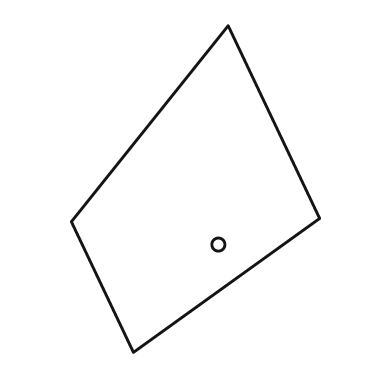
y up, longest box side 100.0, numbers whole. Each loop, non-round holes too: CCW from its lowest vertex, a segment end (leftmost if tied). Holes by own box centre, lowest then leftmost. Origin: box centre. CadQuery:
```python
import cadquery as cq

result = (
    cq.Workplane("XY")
    .moveTo(-19.0, -50.0)
    .lineTo(38.0, -9.0)
    .lineTo(10.0, 50.0)
    .lineTo(-38.0, -10.0)
    .close()
    .moveTo(7.0, -17.0)
    .circle(2.0)
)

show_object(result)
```